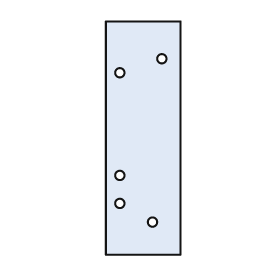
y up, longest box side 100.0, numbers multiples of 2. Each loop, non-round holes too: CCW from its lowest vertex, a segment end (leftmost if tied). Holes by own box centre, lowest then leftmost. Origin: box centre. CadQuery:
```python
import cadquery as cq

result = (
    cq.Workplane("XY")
    .moveTo(-16.0, -50.0)
    .lineTo(16.0, -50.0)
    .lineTo(16.0, 50.0)
    .lineTo(-16.0, 50.0)
    .close()
    .moveTo(4.0, -36.0)
    .circle(2.0)
    .moveTo(-10.0, -28.0)
    .circle(2.0)
    .moveTo(-10.0, -16.0)
    .circle(2.0)
    .moveTo(-10.0, 28.0)
    .circle(2.0)
    .moveTo(8.0, 34.0)
    .circle(2.0)
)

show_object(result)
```